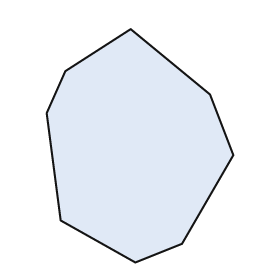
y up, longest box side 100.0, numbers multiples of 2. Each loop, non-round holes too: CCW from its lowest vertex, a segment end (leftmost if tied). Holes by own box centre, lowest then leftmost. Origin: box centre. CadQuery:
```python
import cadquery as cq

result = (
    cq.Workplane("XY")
    .moveTo(-2.0, -50.0)
    .lineTo(18.0, -42.0)
    .lineTo(40.0, -4.0)
    .lineTo(30.0, 22.0)
    .lineTo(-4.0, 50.0)
    .lineTo(-32.0, 32.0)
    .lineTo(-40.0, 14.0)
    .lineTo(-34.0, -32.0)
    .close()
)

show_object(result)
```